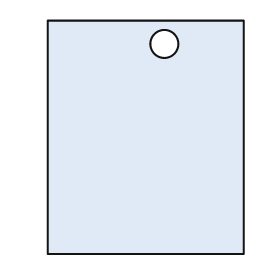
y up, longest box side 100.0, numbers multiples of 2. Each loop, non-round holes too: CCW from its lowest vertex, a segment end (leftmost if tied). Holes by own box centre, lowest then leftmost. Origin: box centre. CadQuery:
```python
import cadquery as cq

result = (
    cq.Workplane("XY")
    .moveTo(-42.0, -50.0)
    .lineTo(42.0, -50.0)
    .lineTo(42.0, 50.0)
    .lineTo(-42.0, 50.0)
    .close()
    .moveTo(8.0, 40.0)
    .circle(6.0)
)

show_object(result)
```